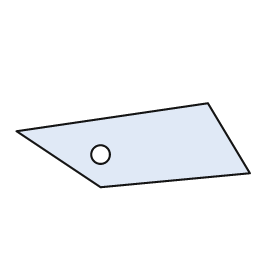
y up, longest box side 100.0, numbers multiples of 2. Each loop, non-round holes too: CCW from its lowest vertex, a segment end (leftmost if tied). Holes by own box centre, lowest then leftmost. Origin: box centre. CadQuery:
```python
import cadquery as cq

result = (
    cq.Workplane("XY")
    .moveTo(-14.0, -18.0)
    .lineTo(50.0, -12.0)
    .lineTo(32.0, 18.0)
    .lineTo(-50.0, 6.0)
    .close()
    .moveTo(-14.0, -4.0)
    .circle(4.0)
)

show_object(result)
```